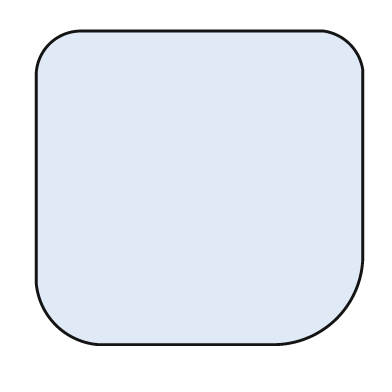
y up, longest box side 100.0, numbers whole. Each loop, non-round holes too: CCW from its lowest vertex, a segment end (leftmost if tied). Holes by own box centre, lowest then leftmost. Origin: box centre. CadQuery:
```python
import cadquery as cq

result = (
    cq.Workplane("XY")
    .moveTo(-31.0, -48.0)
    .lineTo(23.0, -48.0)
    .threePointArc((42.0, -40.0), (50.0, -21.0))
    .lineTo(50.0, 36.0)
    .threePointArc((46.0, 44.0), (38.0, 48.0))
    .lineTo(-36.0, 48.0)
    .threePointArc((-46.0, 44.0), (-50.0, 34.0))
    .lineTo(-50.0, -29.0)
    .threePointArc((-44.0, -42.0), (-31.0, -48.0))
    .close()
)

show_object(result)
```